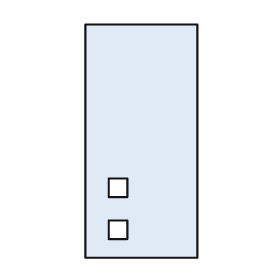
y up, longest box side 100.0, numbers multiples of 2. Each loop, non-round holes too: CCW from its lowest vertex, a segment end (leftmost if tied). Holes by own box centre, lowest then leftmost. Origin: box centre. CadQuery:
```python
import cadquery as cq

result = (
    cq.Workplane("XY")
    .moveTo(-24.0, -50.0)
    .lineTo(24.0, -50.0)
    .lineTo(24.0, 50.0)
    .lineTo(-24.0, 50.0)
    .close()
    .moveTo(-14.0, -42.0)
    .lineTo(-6.0, -42.0)
    .lineTo(-6.0, -34.0)
    .lineTo(-14.0, -34.0)
    .close()
    .moveTo(-14.0, -24.0)
    .lineTo(-6.0, -24.0)
    .lineTo(-6.0, -16.0)
    .lineTo(-14.0, -16.0)
    .close()
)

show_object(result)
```